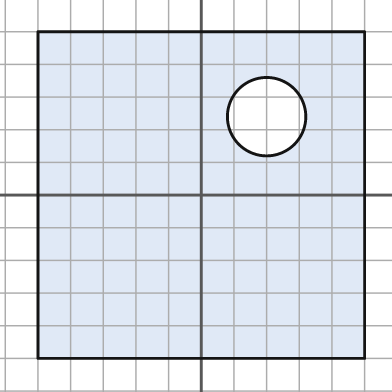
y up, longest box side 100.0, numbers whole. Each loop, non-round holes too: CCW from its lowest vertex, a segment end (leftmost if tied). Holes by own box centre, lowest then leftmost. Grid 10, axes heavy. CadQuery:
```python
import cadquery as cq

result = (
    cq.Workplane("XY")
    .moveTo(-50.0, -50.0)
    .lineTo(50.0, -50.0)
    .lineTo(50.0, 50.0)
    .lineTo(-50.0, 50.0)
    .close()
    .moveTo(20.0, 24.0)
    .circle(12.0)
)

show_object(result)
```